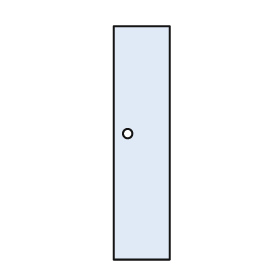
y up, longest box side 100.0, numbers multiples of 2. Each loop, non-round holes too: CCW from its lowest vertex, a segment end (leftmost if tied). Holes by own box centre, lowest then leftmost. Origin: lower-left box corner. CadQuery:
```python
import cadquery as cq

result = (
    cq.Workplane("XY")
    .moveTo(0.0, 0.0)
    .lineTo(24.0, 0.0)
    .lineTo(24.0, 100.0)
    .lineTo(0.0, 100.0)
    .close()
    .moveTo(6.0, 54.0)
    .circle(2.0)
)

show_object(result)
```